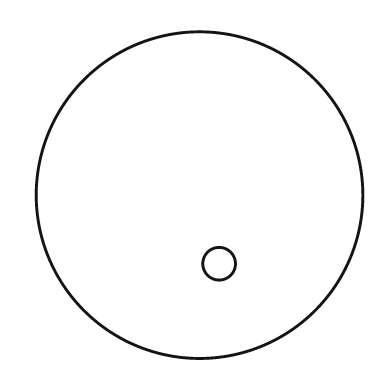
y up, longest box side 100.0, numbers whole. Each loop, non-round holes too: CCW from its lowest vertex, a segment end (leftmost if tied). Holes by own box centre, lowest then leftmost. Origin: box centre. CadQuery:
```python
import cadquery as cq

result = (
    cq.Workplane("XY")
    .moveTo(0.0, 0.0)
    .circle(50.0)
    .moveTo(6.0, -21.0)
    .circle(5.0)
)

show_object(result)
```